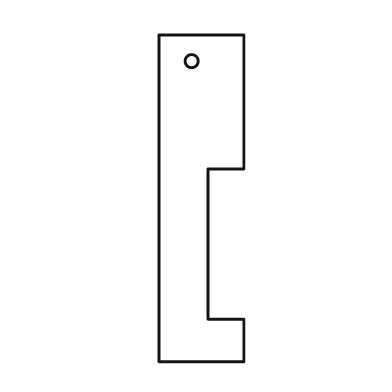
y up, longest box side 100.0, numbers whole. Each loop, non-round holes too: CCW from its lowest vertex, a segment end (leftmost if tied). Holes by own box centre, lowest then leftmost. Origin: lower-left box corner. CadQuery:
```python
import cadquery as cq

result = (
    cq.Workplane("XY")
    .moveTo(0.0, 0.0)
    .lineTo(26.0, 0.0)
    .lineTo(26.0, 13.0)
    .lineTo(15.0, 13.0)
    .lineTo(15.0, 59.0)
    .lineTo(26.0, 59.0)
    .lineTo(26.0, 100.0)
    .lineTo(0.0, 100.0)
    .close()
    .moveTo(10.0, 92.0)
    .circle(2.0)
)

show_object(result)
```